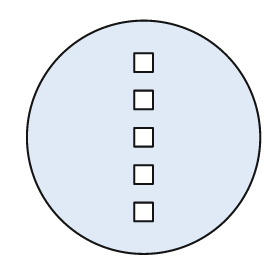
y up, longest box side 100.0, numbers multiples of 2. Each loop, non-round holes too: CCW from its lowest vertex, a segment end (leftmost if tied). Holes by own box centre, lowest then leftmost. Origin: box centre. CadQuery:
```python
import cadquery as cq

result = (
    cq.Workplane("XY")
    .moveTo(0.0, 0.0)
    .circle(50.0)
    .moveTo(-4.0, -36.0)
    .lineTo(4.0, -36.0)
    .lineTo(4.0, -28.0)
    .lineTo(-4.0, -28.0)
    .close()
    .moveTo(-4.0, -20.0)
    .lineTo(4.0, -20.0)
    .lineTo(4.0, -12.0)
    .lineTo(-4.0, -12.0)
    .close()
    .moveTo(-4.0, -4.0)
    .lineTo(4.0, -4.0)
    .lineTo(4.0, 4.0)
    .lineTo(-4.0, 4.0)
    .close()
    .moveTo(-4.0, 12.0)
    .lineTo(4.0, 12.0)
    .lineTo(4.0, 20.0)
    .lineTo(-4.0, 20.0)
    .close()
    .moveTo(-4.0, 28.0)
    .lineTo(4.0, 28.0)
    .lineTo(4.0, 36.0)
    .lineTo(-4.0, 36.0)
    .close()
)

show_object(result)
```